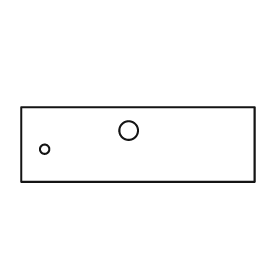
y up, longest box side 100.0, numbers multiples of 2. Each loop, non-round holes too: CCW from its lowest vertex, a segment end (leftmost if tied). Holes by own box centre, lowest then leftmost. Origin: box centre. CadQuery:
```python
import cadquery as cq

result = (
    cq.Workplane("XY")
    .moveTo(-50.0, -16.0)
    .lineTo(50.0, -16.0)
    .lineTo(50.0, 16.0)
    .lineTo(-50.0, 16.0)
    .close()
    .moveTo(-40.0, -2.0)
    .circle(2.0)
    .moveTo(-4.0, 6.0)
    .circle(4.0)
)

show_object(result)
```